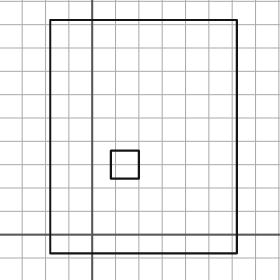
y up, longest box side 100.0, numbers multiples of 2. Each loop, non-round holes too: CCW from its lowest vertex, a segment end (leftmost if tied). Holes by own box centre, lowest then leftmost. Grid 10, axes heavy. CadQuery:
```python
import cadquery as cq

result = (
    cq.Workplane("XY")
    .moveTo(-18.0, -8.0)
    .lineTo(62.0, -8.0)
    .lineTo(62.0, 92.0)
    .lineTo(-18.0, 92.0)
    .close()
    .moveTo(8.0, 24.0)
    .lineTo(20.0, 24.0)
    .lineTo(20.0, 36.0)
    .lineTo(8.0, 36.0)
    .close()
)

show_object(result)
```